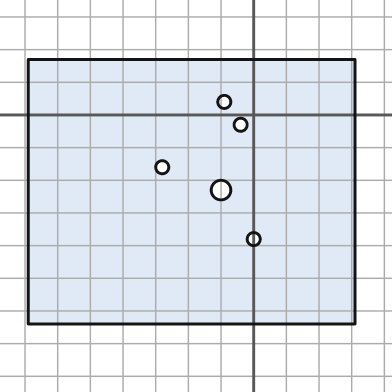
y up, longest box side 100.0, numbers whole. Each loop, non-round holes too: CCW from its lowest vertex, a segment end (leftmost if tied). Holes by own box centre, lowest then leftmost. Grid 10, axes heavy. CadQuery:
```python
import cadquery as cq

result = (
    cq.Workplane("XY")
    .moveTo(-69.0, -64.0)
    .lineTo(31.0, -64.0)
    .lineTo(31.0, 17.0)
    .lineTo(-69.0, 17.0)
    .close()
    .moveTo(0.0, -38.0)
    .circle(2.0)
    .moveTo(-10.0, -23.0)
    .circle(3.0)
    .moveTo(-28.0, -16.0)
    .circle(2.0)
    .moveTo(-4.0, -3.0)
    .circle(2.0)
    .moveTo(-9.0, 4.0)
    .circle(2.0)
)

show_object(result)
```